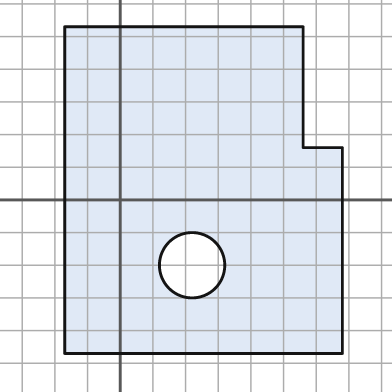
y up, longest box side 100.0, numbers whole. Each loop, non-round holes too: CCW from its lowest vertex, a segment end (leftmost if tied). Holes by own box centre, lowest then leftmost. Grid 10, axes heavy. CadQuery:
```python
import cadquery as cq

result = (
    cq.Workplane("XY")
    .moveTo(-17.0, -47.0)
    .lineTo(68.0, -47.0)
    .lineTo(68.0, 16.0)
    .lineTo(56.0, 16.0)
    .lineTo(56.0, 53.0)
    .lineTo(-17.0, 53.0)
    .close()
    .moveTo(22.0, -20.0)
    .circle(10.0)
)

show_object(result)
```